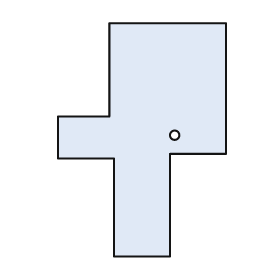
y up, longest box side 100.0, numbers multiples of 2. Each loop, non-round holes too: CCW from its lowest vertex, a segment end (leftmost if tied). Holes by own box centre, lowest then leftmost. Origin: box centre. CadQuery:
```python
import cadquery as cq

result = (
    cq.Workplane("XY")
    .moveTo(-12.0, -50.0)
    .lineTo(12.0, -50.0)
    .lineTo(12.0, -6.0)
    .lineTo(36.0, -6.0)
    .lineTo(36.0, 50.0)
    .lineTo(-14.0, 50.0)
    .lineTo(-14.0, 10.0)
    .lineTo(-36.0, 10.0)
    .lineTo(-36.0, -8.0)
    .lineTo(-12.0, -8.0)
    .close()
    .moveTo(14.0, 2.0)
    .circle(2.0)
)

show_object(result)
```